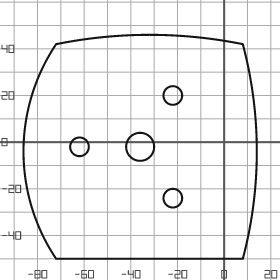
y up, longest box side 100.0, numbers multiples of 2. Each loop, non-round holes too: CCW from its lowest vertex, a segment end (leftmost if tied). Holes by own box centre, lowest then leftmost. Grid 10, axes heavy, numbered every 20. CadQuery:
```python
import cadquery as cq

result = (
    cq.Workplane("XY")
    .moveTo(-72.0, -50.0)
    .lineTo(8.0, -50.0)
    .threePointArc((14.0, -4.0), (8.0, 42.0))
    .threePointArc((-32.0, 46.0), (-72.0, 42.0))
    .threePointArc((-86.0, -4.0), (-72.0, -50.0))
    .close()
    .moveTo(-22.0, -24.0)
    .circle(4.0)
    .moveTo(-62.0, -2.0)
    .circle(4.0)
    .moveTo(-36.0, -2.0)
    .circle(6.0)
    .moveTo(-22.0, 20.0)
    .circle(4.0)
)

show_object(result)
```